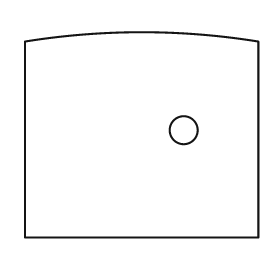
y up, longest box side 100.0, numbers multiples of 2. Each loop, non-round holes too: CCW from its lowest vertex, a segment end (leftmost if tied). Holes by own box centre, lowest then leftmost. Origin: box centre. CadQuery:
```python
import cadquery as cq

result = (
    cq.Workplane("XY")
    .moveTo(-50.0, -44.0)
    .lineTo(50.0, -44.0)
    .lineTo(50.0, 40.0)
    .threePointArc((0.0, 44.0), (-50.0, 40.0))
    .close()
    .moveTo(18.0, 2.0)
    .circle(6.0)
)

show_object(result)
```